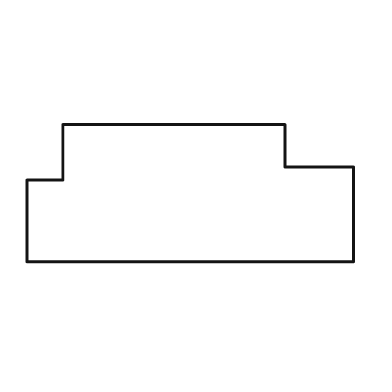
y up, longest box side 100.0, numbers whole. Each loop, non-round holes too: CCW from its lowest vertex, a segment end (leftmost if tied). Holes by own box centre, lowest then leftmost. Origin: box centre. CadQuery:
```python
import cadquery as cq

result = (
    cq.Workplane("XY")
    .moveTo(-50.0, -21.0)
    .lineTo(50.0, -21.0)
    .lineTo(50.0, 8.0)
    .lineTo(29.0, 8.0)
    .lineTo(29.0, 21.0)
    .lineTo(-39.0, 21.0)
    .lineTo(-39.0, 4.0)
    .lineTo(-50.0, 4.0)
    .close()
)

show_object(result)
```